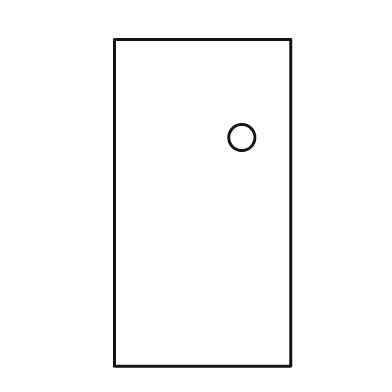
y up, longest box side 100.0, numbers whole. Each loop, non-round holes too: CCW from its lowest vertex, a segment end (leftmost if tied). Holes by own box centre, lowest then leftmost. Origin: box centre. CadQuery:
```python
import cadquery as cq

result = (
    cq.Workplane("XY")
    .moveTo(-27.0, -50.0)
    .lineTo(27.0, -50.0)
    .lineTo(27.0, 50.0)
    .lineTo(-27.0, 50.0)
    .close()
    .moveTo(12.0, 20.0)
    .circle(4.0)
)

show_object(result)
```